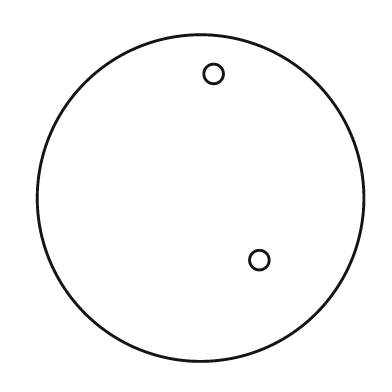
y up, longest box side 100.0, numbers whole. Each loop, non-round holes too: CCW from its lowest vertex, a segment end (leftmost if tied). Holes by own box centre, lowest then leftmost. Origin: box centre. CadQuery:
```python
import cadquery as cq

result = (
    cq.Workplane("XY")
    .moveTo(0.0, 0.0)
    .circle(50.0)
    .moveTo(18.0, -19.0)
    .circle(3.0)
    .moveTo(4.0, 38.0)
    .circle(3.0)
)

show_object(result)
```